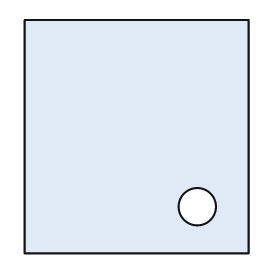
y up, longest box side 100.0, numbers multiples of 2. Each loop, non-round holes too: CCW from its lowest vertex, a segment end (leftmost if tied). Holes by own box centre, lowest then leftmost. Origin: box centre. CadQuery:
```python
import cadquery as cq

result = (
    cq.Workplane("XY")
    .moveTo(-48.0, -50.0)
    .lineTo(48.0, -50.0)
    .lineTo(48.0, 50.0)
    .lineTo(-48.0, 50.0)
    .close()
    .moveTo(26.0, -30.0)
    .circle(8.0)
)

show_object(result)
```